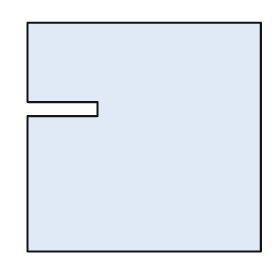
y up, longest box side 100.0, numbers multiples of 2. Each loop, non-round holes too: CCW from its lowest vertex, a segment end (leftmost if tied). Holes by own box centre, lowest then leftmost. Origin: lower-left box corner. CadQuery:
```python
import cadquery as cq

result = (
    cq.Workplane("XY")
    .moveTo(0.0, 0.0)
    .lineTo(100.0, 0.0)
    .lineTo(100.0, 98.0)
    .lineTo(0.0, 98.0)
    .lineTo(0.0, 64.0)
    .lineTo(30.0, 64.0)
    .lineTo(30.0, 58.0)
    .lineTo(0.0, 58.0)
    .close()
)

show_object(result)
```